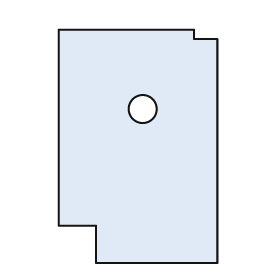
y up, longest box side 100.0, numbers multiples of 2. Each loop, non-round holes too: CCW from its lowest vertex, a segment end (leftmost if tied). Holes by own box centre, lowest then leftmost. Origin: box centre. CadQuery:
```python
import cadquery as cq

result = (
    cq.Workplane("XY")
    .moveTo(-18.0, -50.0)
    .lineTo(34.0, -50.0)
    .lineTo(34.0, 46.0)
    .lineTo(24.0, 46.0)
    .lineTo(24.0, 50.0)
    .lineTo(-34.0, 50.0)
    .lineTo(-34.0, -34.0)
    .lineTo(-18.0, -34.0)
    .close()
    .moveTo(2.0, 16.0)
    .circle(6.0)
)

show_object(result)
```